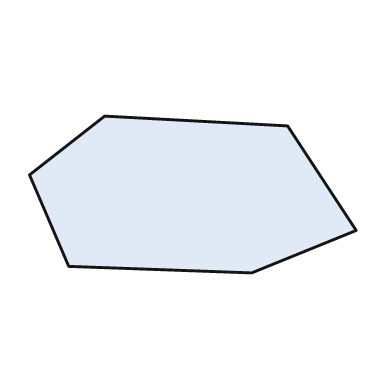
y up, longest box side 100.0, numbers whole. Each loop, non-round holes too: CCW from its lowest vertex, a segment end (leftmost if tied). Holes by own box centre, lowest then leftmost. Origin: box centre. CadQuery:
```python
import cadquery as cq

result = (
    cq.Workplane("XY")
    .moveTo(18.0, -24.0)
    .lineTo(50.0, -11.0)
    .lineTo(29.0, 21.0)
    .lineTo(-27.0, 24.0)
    .lineTo(-50.0, 6.0)
    .lineTo(-38.0, -22.0)
    .close()
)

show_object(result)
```